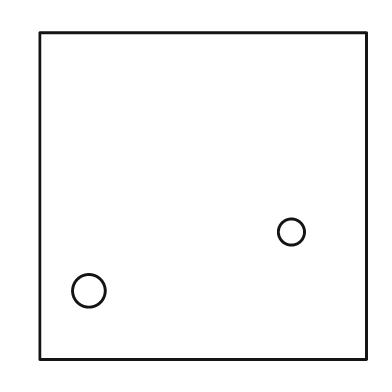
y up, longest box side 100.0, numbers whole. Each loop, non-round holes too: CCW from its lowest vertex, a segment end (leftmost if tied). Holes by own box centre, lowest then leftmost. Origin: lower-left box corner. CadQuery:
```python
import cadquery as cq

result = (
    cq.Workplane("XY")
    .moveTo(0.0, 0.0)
    .lineTo(100.0, 0.0)
    .lineTo(100.0, 100.0)
    .lineTo(0.0, 100.0)
    .close()
    .moveTo(15.0, 21.0)
    .circle(5.0)
    .moveTo(77.0, 39.0)
    .circle(4.0)
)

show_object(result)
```